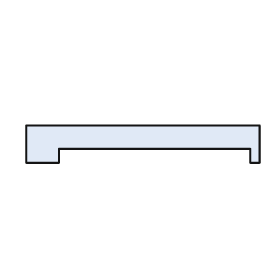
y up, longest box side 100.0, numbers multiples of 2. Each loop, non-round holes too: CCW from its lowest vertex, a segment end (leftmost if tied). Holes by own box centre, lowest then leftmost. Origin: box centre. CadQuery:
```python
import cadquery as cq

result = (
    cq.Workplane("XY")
    .moveTo(-50.0, -8.0)
    .lineTo(-36.0, -8.0)
    .lineTo(-36.0, -2.0)
    .lineTo(46.0, -2.0)
    .lineTo(46.0, -8.0)
    .lineTo(50.0, -8.0)
    .lineTo(50.0, 8.0)
    .lineTo(-50.0, 8.0)
    .close()
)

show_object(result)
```